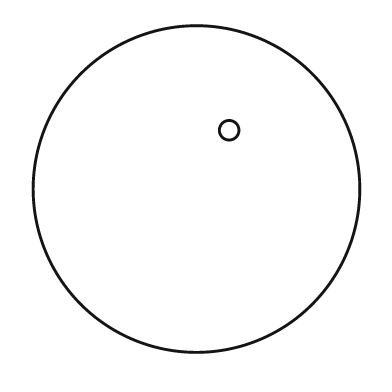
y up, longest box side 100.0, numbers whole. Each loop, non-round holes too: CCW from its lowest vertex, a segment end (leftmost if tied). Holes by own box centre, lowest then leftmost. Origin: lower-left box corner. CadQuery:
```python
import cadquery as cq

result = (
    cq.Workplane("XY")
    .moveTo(50.0, 50.0)
    .circle(50.0)
    .moveTo(60.0, 68.0)
    .circle(3.0)
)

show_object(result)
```